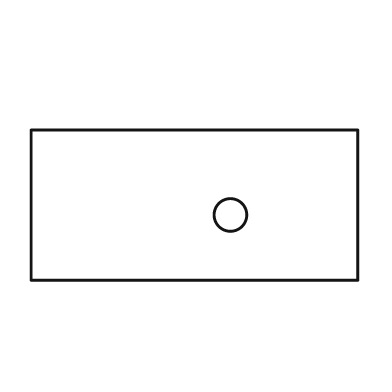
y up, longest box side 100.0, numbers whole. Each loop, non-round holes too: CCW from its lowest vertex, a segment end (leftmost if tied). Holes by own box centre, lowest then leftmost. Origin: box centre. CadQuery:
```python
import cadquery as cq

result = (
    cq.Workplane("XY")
    .moveTo(-50.0, -23.0)
    .lineTo(50.0, -23.0)
    .lineTo(50.0, 23.0)
    .lineTo(-50.0, 23.0)
    .close()
    .moveTo(11.0, -3.0)
    .circle(5.0)
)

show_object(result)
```